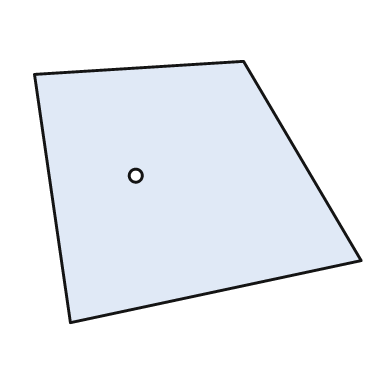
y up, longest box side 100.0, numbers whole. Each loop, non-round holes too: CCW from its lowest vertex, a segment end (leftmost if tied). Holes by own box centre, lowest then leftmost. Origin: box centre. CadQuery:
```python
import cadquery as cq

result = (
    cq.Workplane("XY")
    .moveTo(-39.0, -40.0)
    .lineTo(50.0, -21.0)
    .lineTo(14.0, 40.0)
    .lineTo(-50.0, 36.0)
    .close()
    .moveTo(-19.0, 5.0)
    .circle(2.0)
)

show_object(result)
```